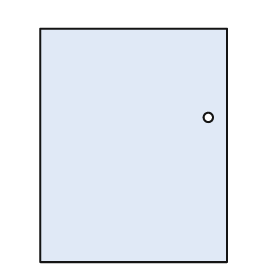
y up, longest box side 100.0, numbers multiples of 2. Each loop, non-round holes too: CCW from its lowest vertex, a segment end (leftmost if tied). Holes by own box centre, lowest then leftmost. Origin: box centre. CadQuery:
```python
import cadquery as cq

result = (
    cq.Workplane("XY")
    .moveTo(-40.0, -50.0)
    .lineTo(40.0, -50.0)
    .lineTo(40.0, 50.0)
    .lineTo(-40.0, 50.0)
    .close()
    .moveTo(32.0, 12.0)
    .circle(2.0)
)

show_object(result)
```